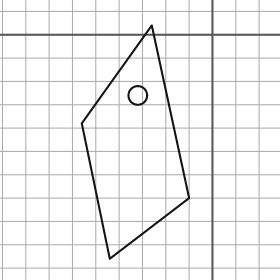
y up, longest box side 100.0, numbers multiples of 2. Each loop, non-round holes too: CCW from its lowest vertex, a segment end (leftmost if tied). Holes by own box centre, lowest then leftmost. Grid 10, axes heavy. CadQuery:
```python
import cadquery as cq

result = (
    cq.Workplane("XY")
    .moveTo(-44.0, -96.0)
    .lineTo(-10.0, -70.0)
    .lineTo(-26.0, 4.0)
    .lineTo(-56.0, -38.0)
    .close()
    .moveTo(-32.0, -26.0)
    .circle(4.0)
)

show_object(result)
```